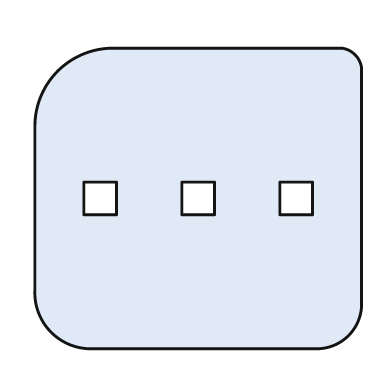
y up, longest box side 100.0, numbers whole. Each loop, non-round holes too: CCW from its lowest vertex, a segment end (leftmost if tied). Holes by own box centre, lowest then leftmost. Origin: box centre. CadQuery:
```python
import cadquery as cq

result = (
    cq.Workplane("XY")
    .moveTo(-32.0, -46.0)
    .lineTo(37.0, -46.0)
    .threePointArc((46.0, -42.0), (50.0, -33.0))
    .lineTo(50.0, 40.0)
    .threePointArc((48.0, 44.0), (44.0, 46.0))
    .lineTo(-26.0, 46.0)
    .threePointArc((-43.0, 39.0), (-50.0, 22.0))
    .lineTo(-50.0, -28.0)
    .threePointArc((-45.0, -41.0), (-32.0, -46.0))
    .close()
    .moveTo(-35.0, -5.0)
    .lineTo(-25.0, -5.0)
    .lineTo(-25.0, 5.0)
    .lineTo(-35.0, 5.0)
    .close()
    .moveTo(-5.0, -5.0)
    .lineTo(5.0, -5.0)
    .lineTo(5.0, 5.0)
    .lineTo(-5.0, 5.0)
    .close()
    .moveTo(25.0, -5.0)
    .lineTo(35.0, -5.0)
    .lineTo(35.0, 5.0)
    .lineTo(25.0, 5.0)
    .close()
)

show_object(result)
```